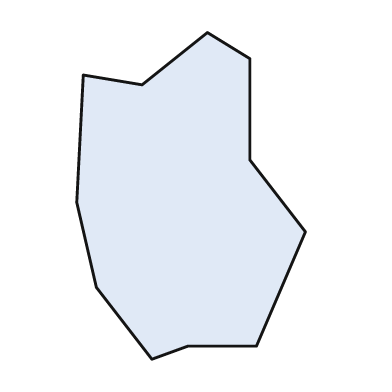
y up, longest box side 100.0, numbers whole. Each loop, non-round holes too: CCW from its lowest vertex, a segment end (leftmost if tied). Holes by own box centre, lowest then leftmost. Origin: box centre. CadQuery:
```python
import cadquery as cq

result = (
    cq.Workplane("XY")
    .moveTo(-12.0, -50.0)
    .lineTo(-1.0, -46.0)
    .lineTo(20.0, -46.0)
    .lineTo(35.0, -11.0)
    .lineTo(18.0, 11.0)
    .lineTo(18.0, 42.0)
    .lineTo(5.0, 50.0)
    .lineTo(-15.0, 34.0)
    .lineTo(-33.0, 37.0)
    .lineTo(-35.0, -2.0)
    .lineTo(-29.0, -28.0)
    .close()
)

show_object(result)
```